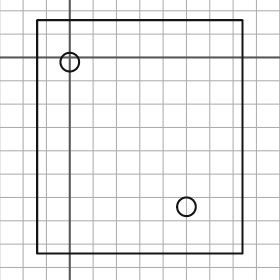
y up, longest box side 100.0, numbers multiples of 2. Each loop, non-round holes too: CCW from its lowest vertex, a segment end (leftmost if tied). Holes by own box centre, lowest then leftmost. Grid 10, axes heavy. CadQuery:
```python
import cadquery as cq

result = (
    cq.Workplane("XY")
    .moveTo(-14.0, -84.0)
    .lineTo(74.0, -84.0)
    .lineTo(74.0, 16.0)
    .lineTo(-14.0, 16.0)
    .close()
    .moveTo(50.0, -64.0)
    .circle(4.0)
    .moveTo(0.0, -2.0)
    .circle(4.0)
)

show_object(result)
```